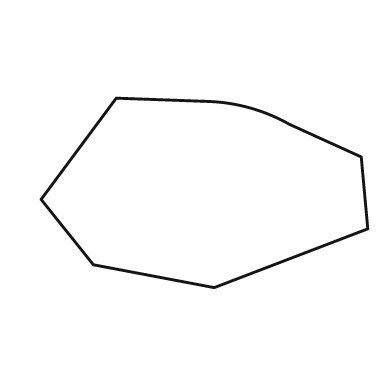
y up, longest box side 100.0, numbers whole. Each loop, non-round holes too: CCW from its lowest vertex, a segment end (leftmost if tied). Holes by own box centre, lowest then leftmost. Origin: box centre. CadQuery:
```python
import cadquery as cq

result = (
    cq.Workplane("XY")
    .moveTo(3.0, -29.0)
    .lineTo(50.0, -11.0)
    .lineTo(48.0, 11.0)
    .lineTo(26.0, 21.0)
    .threePointArc((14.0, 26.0), (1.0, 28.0))
    .lineTo(-27.0, 29.0)
    .lineTo(-50.0, -2.0)
    .lineTo(-34.0, -22.0)
    .close()
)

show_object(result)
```